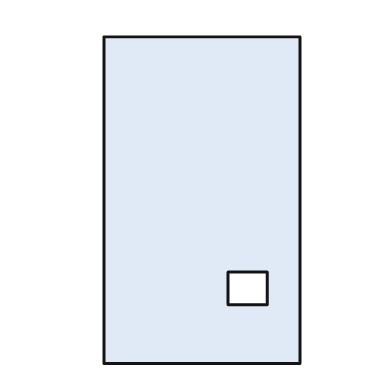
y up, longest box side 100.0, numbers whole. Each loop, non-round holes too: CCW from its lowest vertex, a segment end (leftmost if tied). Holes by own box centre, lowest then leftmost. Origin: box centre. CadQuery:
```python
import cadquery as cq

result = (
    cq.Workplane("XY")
    .moveTo(-30.0, -50.0)
    .lineTo(30.0, -50.0)
    .lineTo(30.0, 50.0)
    .lineTo(-30.0, 50.0)
    .close()
    .moveTo(8.0, -32.0)
    .lineTo(20.0, -32.0)
    .lineTo(20.0, -22.0)
    .lineTo(8.0, -22.0)
    .close()
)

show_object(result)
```